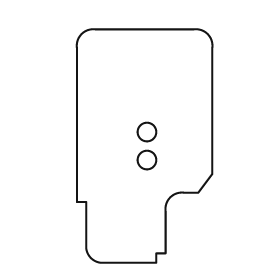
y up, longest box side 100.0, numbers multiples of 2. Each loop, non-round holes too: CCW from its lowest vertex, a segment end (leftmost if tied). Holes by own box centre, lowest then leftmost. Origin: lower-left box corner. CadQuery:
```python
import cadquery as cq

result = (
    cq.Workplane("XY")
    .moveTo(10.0, 0.0)
    .lineTo(34.0, 0.0)
    .lineTo(34.0, 4.0)
    .lineTo(38.0, 4.0)
    .lineTo(38.0, 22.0)
    .threePointArc((40.0, 28.0), (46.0, 30.0))
    .lineTo(52.0, 30.0)
    .lineTo(58.0, 38.0)
    .lineTo(58.0, 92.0)
    .threePointArc((56.0, 98.0), (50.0, 100.0))
    .lineTo(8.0, 100.0)
    .threePointArc((2.0, 98.0), (0.0, 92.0))
    .lineTo(0.0, 26.0)
    .lineTo(4.0, 26.0)
    .lineTo(4.0, 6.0)
    .threePointArc((6.0, 2.0), (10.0, 0.0))
    .close()
    .moveTo(30.0, 44.0)
    .circle(4.0)
    .moveTo(30.0, 56.0)
    .circle(4.0)
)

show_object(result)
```